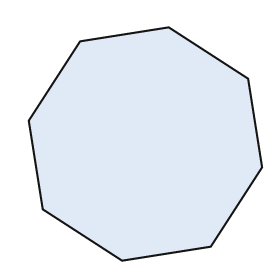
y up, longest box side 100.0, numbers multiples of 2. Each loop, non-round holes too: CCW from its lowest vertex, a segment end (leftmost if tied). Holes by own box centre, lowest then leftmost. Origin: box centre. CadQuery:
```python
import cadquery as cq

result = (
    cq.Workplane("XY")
    .moveTo(-10.0, -50.0)
    .lineTo(28.0, -44.0)
    .lineTo(50.0, -10.0)
    .lineTo(44.0, 28.0)
    .lineTo(10.0, 50.0)
    .lineTo(-28.0, 44.0)
    .lineTo(-50.0, 10.0)
    .lineTo(-44.0, -28.0)
    .close()
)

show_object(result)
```